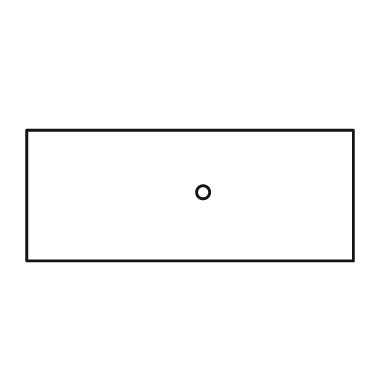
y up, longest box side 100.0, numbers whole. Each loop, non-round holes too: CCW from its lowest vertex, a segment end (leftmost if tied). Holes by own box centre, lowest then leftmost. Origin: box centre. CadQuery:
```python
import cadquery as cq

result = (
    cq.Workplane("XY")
    .moveTo(-50.0, -20.0)
    .lineTo(50.0, -20.0)
    .lineTo(50.0, 20.0)
    .lineTo(-50.0, 20.0)
    .close()
    .moveTo(4.0, 1.0)
    .circle(2.0)
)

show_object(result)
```